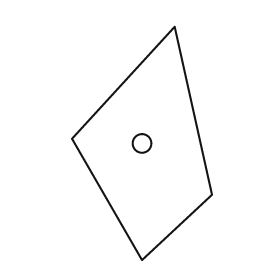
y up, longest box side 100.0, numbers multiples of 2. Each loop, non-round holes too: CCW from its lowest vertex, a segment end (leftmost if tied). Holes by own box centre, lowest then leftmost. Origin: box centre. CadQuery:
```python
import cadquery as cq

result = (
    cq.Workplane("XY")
    .moveTo(0.0, -50.0)
    .lineTo(30.0, -22.0)
    .lineTo(14.0, 50.0)
    .lineTo(-30.0, 2.0)
    .close()
    .moveTo(0.0, 0.0)
    .circle(4.0)
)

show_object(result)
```